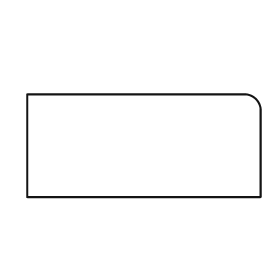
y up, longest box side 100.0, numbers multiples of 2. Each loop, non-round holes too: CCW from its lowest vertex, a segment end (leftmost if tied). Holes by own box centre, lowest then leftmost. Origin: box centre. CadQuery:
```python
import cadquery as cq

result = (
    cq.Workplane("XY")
    .moveTo(-50.0, -22.0)
    .lineTo(50.0, -22.0)
    .lineTo(50.0, 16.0)
    .threePointArc((48.0, 20.0), (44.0, 22.0))
    .lineTo(-50.0, 22.0)
    .close()
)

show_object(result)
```